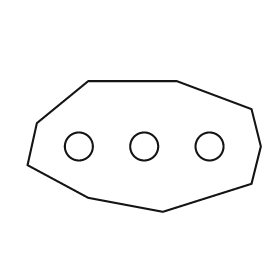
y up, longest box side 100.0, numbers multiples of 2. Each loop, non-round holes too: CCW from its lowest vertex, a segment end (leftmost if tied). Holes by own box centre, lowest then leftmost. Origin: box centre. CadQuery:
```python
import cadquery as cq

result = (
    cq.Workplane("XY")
    .moveTo(8.0, -28.0)
    .lineTo(46.0, -16.0)
    .lineTo(50.0, 0.0)
    .lineTo(46.0, 16.0)
    .lineTo(14.0, 28.0)
    .lineTo(-24.0, 28.0)
    .lineTo(-46.0, 10.0)
    .lineTo(-50.0, -8.0)
    .lineTo(-24.0, -22.0)
    .close()
    .moveTo(-28.0, 0.0)
    .circle(6.0)
    .moveTo(0.0, 0.0)
    .circle(6.0)
    .moveTo(28.0, 0.0)
    .circle(6.0)
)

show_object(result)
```